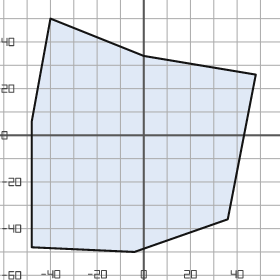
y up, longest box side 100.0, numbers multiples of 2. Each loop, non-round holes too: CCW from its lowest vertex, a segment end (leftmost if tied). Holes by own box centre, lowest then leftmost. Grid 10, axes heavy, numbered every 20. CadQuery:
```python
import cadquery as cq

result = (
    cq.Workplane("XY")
    .moveTo(-4.0, -50.0)
    .lineTo(36.0, -36.0)
    .lineTo(48.0, 26.0)
    .lineTo(0.0, 34.0)
    .lineTo(-40.0, 50.0)
    .lineTo(-48.0, 6.0)
    .lineTo(-48.0, -48.0)
    .close()
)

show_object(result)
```